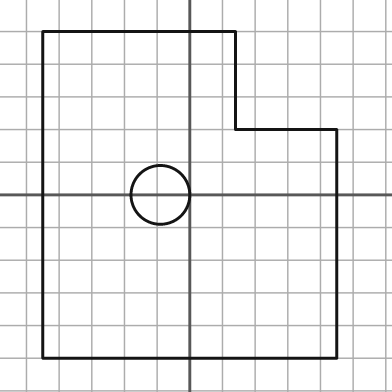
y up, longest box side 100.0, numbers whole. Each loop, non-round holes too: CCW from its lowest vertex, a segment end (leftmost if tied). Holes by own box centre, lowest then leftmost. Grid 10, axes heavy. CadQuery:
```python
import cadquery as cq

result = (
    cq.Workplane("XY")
    .moveTo(-45.0, -50.0)
    .lineTo(45.0, -50.0)
    .lineTo(45.0, 20.0)
    .lineTo(14.0, 20.0)
    .lineTo(14.0, 50.0)
    .lineTo(-45.0, 50.0)
    .close()
    .moveTo(-9.0, 0.0)
    .circle(9.0)
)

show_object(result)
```